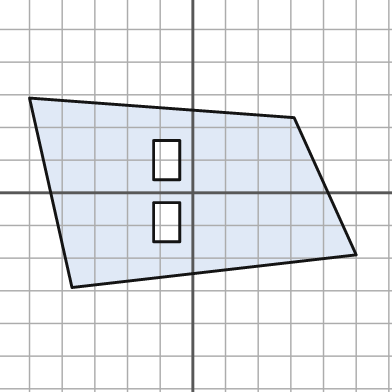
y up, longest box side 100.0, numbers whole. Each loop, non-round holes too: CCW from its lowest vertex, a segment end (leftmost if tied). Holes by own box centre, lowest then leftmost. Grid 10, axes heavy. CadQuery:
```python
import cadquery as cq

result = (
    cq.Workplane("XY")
    .moveTo(-37.0, -29.0)
    .lineTo(50.0, -19.0)
    .lineTo(31.0, 23.0)
    .lineTo(-50.0, 29.0)
    .close()
    .moveTo(-12.0, -15.0)
    .lineTo(-4.0, -15.0)
    .lineTo(-4.0, -3.0)
    .lineTo(-12.0, -3.0)
    .close()
    .moveTo(-12.0, 4.0)
    .lineTo(-4.0, 4.0)
    .lineTo(-4.0, 16.0)
    .lineTo(-12.0, 16.0)
    .close()
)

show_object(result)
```